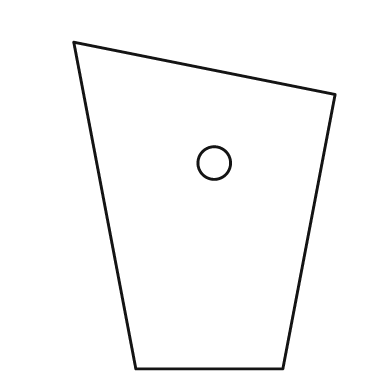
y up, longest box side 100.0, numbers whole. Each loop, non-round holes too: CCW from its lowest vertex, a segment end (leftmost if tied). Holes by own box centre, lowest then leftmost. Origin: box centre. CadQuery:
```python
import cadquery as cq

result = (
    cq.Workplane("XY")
    .moveTo(-21.0, -50.0)
    .lineTo(24.0, -50.0)
    .lineTo(40.0, 34.0)
    .lineTo(-40.0, 50.0)
    .close()
    .moveTo(3.0, 13.0)
    .circle(5.0)
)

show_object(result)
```